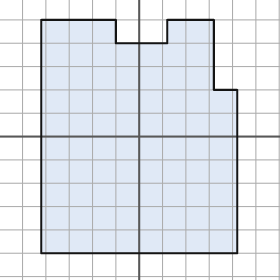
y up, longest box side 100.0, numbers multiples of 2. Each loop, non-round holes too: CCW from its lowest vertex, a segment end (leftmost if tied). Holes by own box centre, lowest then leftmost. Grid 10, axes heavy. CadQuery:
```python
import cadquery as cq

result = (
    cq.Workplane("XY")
    .moveTo(-42.0, -50.0)
    .lineTo(42.0, -50.0)
    .lineTo(42.0, 20.0)
    .lineTo(32.0, 20.0)
    .lineTo(32.0, 50.0)
    .lineTo(12.0, 50.0)
    .lineTo(12.0, 40.0)
    .lineTo(-10.0, 40.0)
    .lineTo(-10.0, 50.0)
    .lineTo(-42.0, 50.0)
    .close()
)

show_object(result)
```